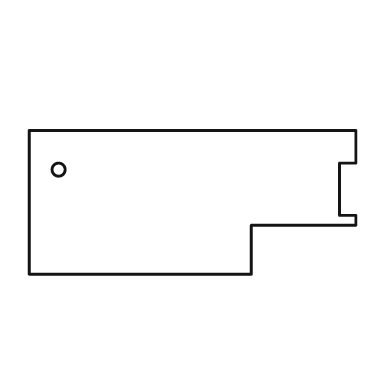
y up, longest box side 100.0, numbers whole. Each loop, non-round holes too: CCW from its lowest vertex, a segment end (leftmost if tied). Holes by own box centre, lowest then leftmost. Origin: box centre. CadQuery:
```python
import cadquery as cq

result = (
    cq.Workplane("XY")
    .moveTo(-50.0, -22.0)
    .lineTo(18.0, -22.0)
    .lineTo(18.0, -7.0)
    .lineTo(50.0, -7.0)
    .lineTo(50.0, -4.0)
    .lineTo(45.0, -4.0)
    .lineTo(45.0, 12.0)
    .lineTo(50.0, 12.0)
    .lineTo(50.0, 22.0)
    .lineTo(-50.0, 22.0)
    .close()
    .moveTo(-41.0, 10.0)
    .circle(2.0)
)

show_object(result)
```